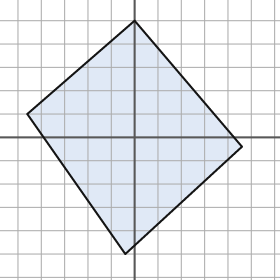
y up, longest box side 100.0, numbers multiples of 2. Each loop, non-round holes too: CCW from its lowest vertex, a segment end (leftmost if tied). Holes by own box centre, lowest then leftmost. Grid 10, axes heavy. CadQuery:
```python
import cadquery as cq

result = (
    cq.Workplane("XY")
    .moveTo(-4.0, -50.0)
    .lineTo(46.0, -4.0)
    .lineTo(0.0, 50.0)
    .lineTo(-46.0, 10.0)
    .close()
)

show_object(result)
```